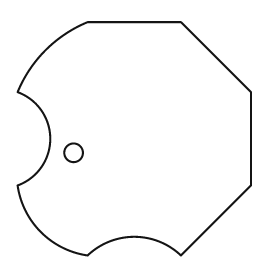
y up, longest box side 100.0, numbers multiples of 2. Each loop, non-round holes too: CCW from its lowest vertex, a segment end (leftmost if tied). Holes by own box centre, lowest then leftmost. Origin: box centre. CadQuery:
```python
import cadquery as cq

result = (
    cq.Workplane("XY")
    .moveTo(-20.0, -50.0)
    .threePointArc((0.0, -42.0), (20.0, -50.0))
    .lineTo(50.0, -20.0)
    .lineTo(50.0, 20.0)
    .lineTo(20.0, 50.0)
    .lineTo(-20.0, 50.0)
    .threePointArc((-38.0, 38.0), (-50.0, 20.0))
    .threePointArc((-36.0, 0.0), (-50.0, -20.0))
    .threePointArc((-40.0, -40.0), (-20.0, -50.0))
    .close()
    .moveTo(-26.0, -6.0)
    .circle(4.0)
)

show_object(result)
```